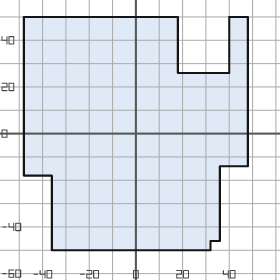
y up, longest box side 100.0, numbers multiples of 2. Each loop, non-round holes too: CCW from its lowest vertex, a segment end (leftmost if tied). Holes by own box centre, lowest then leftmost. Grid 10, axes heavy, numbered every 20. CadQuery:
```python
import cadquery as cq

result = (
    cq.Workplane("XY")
    .moveTo(-36.0, -50.0)
    .lineTo(32.0, -50.0)
    .lineTo(32.0, -46.0)
    .lineTo(36.0, -46.0)
    .lineTo(36.0, -14.0)
    .lineTo(48.0, -14.0)
    .lineTo(48.0, 50.0)
    .lineTo(40.0, 50.0)
    .lineTo(40.0, 26.0)
    .lineTo(18.0, 26.0)
    .lineTo(18.0, 50.0)
    .lineTo(-48.0, 50.0)
    .lineTo(-48.0, -18.0)
    .lineTo(-36.0, -18.0)
    .close()
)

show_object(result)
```